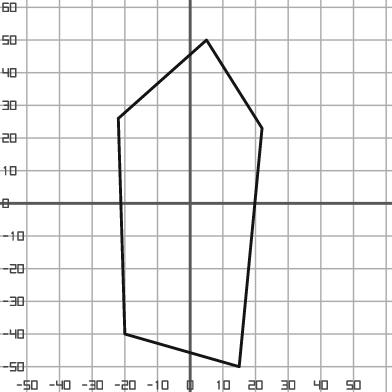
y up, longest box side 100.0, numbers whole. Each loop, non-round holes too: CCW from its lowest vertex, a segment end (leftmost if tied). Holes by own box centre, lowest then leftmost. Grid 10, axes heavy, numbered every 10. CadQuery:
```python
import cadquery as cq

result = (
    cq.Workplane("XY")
    .moveTo(15.0, -50.0)
    .lineTo(22.0, 23.0)
    .lineTo(5.0, 50.0)
    .lineTo(-22.0, 26.0)
    .lineTo(-20.0, -40.0)
    .close()
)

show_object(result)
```